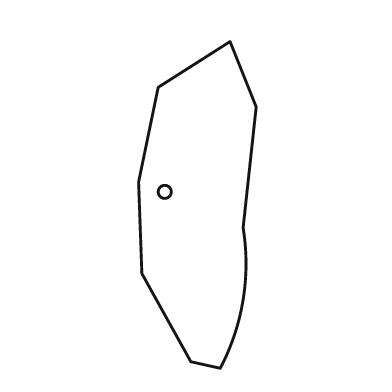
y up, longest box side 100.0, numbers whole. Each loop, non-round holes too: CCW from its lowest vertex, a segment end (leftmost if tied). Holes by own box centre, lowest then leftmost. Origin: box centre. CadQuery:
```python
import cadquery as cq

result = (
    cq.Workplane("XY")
    .moveTo(7.0, -50.0)
    .threePointArc((14.0, -29.0), (14.0, -7.0))
    .lineTo(18.0, 30.0)
    .lineTo(10.0, 50.0)
    .lineTo(-12.0, 36.0)
    .lineTo(-18.0, 7.0)
    .lineTo(-17.0, -21.0)
    .lineTo(-2.0, -48.0)
    .close()
    .moveTo(-10.0, 4.0)
    .circle(2.0)
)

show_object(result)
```